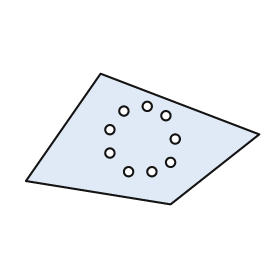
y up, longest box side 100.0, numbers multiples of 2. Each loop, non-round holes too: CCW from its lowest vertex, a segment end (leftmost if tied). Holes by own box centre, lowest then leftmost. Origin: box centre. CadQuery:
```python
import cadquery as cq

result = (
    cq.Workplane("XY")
    .moveTo(12.0, -28.0)
    .lineTo(50.0, 2.0)
    .lineTo(-18.0, 28.0)
    .lineTo(-50.0, -18.0)
    .close()
    .moveTo(-6.0, -14.0)
    .circle(2.0)
    .moveTo(4.0, -14.0)
    .circle(2.0)
    .moveTo(12.0, -10.0)
    .circle(2.0)
    .moveTo(-14.0, -6.0)
    .circle(2.0)
    .moveTo(14.0, 0.0)
    .circle(2.0)
    .moveTo(-14.0, 4.0)
    .circle(2.0)
    .moveTo(10.0, 10.0)
    .circle(2.0)
    .moveTo(-8.0, 12.0)
    .circle(2.0)
    .moveTo(2.0, 14.0)
    .circle(2.0)
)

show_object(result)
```